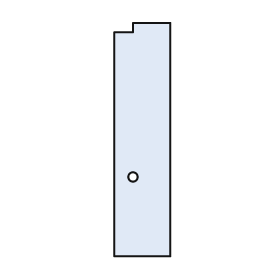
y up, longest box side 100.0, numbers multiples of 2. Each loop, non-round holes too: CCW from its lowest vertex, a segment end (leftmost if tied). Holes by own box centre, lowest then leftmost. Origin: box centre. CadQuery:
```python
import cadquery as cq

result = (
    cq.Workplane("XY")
    .moveTo(-12.0, -50.0)
    .lineTo(12.0, -50.0)
    .lineTo(12.0, 50.0)
    .lineTo(-4.0, 50.0)
    .lineTo(-4.0, 46.0)
    .lineTo(-12.0, 46.0)
    .close()
    .moveTo(-4.0, -16.0)
    .circle(2.0)
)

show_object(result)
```